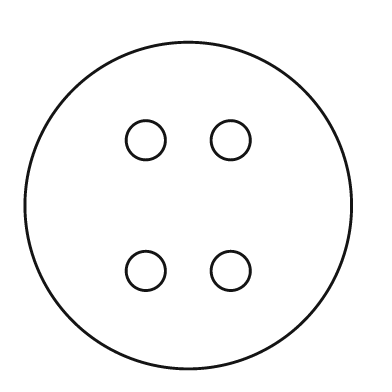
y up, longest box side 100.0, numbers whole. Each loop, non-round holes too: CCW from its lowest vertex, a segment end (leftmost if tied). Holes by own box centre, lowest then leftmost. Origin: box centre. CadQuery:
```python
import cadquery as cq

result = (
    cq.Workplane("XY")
    .moveTo(0.0, 0.0)
    .circle(50.0)
    .moveTo(-13.0, -20.0)
    .circle(6.0)
    .moveTo(13.0, -20.0)
    .circle(6.0)
    .moveTo(-13.0, 20.0)
    .circle(6.0)
    .moveTo(13.0, 20.0)
    .circle(6.0)
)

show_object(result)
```